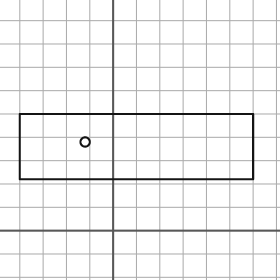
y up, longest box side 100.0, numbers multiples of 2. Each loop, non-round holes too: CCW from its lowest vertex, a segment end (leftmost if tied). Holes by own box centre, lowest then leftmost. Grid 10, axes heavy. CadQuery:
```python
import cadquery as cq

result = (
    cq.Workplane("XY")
    .moveTo(-40.0, 22.0)
    .lineTo(60.0, 22.0)
    .lineTo(60.0, 50.0)
    .lineTo(-40.0, 50.0)
    .close()
    .moveTo(-12.0, 38.0)
    .circle(2.0)
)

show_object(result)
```